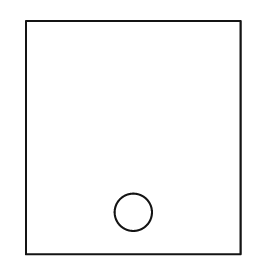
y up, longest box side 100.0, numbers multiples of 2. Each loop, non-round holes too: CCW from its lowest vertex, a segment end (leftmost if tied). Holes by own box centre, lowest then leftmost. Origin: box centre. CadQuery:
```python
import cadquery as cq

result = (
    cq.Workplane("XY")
    .moveTo(-46.0, -50.0)
    .lineTo(46.0, -50.0)
    .lineTo(46.0, 50.0)
    .lineTo(-46.0, 50.0)
    .close()
    .moveTo(0.0, -32.0)
    .circle(8.0)
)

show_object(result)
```